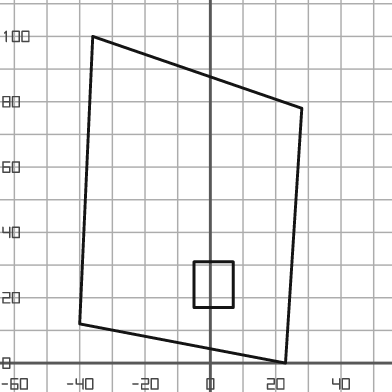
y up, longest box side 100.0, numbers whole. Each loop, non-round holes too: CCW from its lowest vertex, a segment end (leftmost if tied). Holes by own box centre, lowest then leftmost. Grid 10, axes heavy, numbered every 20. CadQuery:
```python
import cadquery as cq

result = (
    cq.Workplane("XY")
    .moveTo(23.0, 0.0)
    .lineTo(28.0, 78.0)
    .lineTo(-36.0, 100.0)
    .lineTo(-40.0, 12.0)
    .close()
    .moveTo(-5.0, 17.0)
    .lineTo(7.0, 17.0)
    .lineTo(7.0, 31.0)
    .lineTo(-5.0, 31.0)
    .close()
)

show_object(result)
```